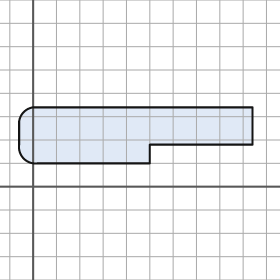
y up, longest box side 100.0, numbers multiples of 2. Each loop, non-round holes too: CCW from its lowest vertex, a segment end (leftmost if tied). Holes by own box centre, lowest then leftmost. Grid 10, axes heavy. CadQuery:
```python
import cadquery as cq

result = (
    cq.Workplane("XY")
    .moveTo(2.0, 10.0)
    .lineTo(50.0, 10.0)
    .lineTo(50.0, 18.0)
    .lineTo(94.0, 18.0)
    .lineTo(94.0, 34.0)
    .lineTo(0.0, 34.0)
    .threePointArc((-4.0, 32.0), (-6.0, 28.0))
    .lineTo(-6.0, 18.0)
    .threePointArc((-4.0, 12.0), (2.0, 10.0))
    .close()
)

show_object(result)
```